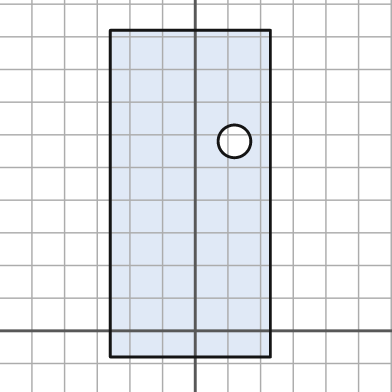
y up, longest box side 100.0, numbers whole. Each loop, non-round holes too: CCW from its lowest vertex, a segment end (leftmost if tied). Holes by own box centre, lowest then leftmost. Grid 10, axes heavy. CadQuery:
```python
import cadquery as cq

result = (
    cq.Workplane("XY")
    .moveTo(-26.0, -8.0)
    .lineTo(23.0, -8.0)
    .lineTo(23.0, 92.0)
    .lineTo(-26.0, 92.0)
    .close()
    .moveTo(12.0, 58.0)
    .circle(5.0)
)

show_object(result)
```